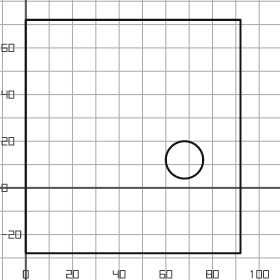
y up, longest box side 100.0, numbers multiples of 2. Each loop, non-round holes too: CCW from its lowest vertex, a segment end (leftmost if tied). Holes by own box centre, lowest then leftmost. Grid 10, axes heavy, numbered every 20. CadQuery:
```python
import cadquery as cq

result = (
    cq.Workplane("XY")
    .moveTo(0.0, -28.0)
    .lineTo(92.0, -28.0)
    .lineTo(92.0, 72.0)
    .lineTo(0.0, 72.0)
    .close()
    .moveTo(68.0, 12.0)
    .circle(8.0)
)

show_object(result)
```